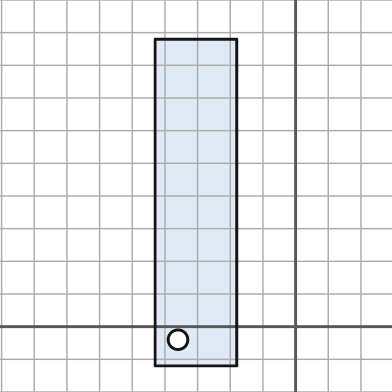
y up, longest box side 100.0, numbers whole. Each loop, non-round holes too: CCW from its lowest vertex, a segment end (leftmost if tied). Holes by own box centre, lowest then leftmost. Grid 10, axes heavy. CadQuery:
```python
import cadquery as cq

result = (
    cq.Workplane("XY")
    .moveTo(-43.0, -12.0)
    .lineTo(-18.0, -12.0)
    .lineTo(-18.0, 88.0)
    .lineTo(-43.0, 88.0)
    .close()
    .moveTo(-36.0, -4.0)
    .circle(3.0)
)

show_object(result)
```